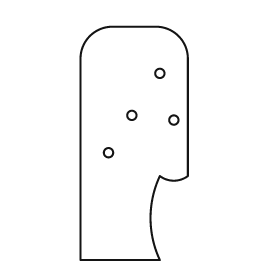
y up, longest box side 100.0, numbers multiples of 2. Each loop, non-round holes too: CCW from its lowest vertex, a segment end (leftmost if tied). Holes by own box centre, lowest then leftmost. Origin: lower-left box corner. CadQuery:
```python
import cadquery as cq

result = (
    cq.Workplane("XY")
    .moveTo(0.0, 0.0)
    .lineTo(34.0, 0.0)
    .threePointArc((30.0, 18.0), (34.0, 36.0))
    .threePointArc((40.0, 34.0), (46.0, 36.0))
    .lineTo(46.0, 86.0)
    .threePointArc((42.0, 96.0), (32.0, 100.0))
    .lineTo(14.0, 100.0)
    .threePointArc((4.0, 96.0), (0.0, 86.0))
    .close()
    .moveTo(12.0, 46.0)
    .circle(2.0)
    .moveTo(40.0, 60.0)
    .circle(2.0)
    .moveTo(22.0, 62.0)
    .circle(2.0)
    .moveTo(34.0, 80.0)
    .circle(2.0)
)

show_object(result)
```